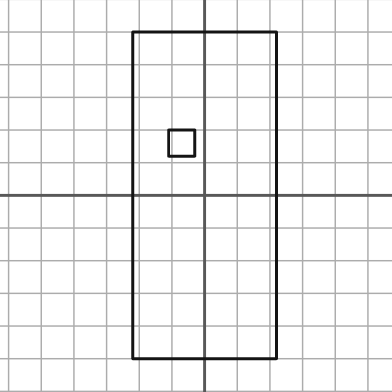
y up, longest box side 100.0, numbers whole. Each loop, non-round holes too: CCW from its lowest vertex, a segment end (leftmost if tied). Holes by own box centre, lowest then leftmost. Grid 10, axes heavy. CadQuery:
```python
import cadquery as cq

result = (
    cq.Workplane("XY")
    .moveTo(-22.0, -50.0)
    .lineTo(22.0, -50.0)
    .lineTo(22.0, 50.0)
    .lineTo(-22.0, 50.0)
    .close()
    .moveTo(-11.0, 12.0)
    .lineTo(-3.0, 12.0)
    .lineTo(-3.0, 20.0)
    .lineTo(-11.0, 20.0)
    .close()
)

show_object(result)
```